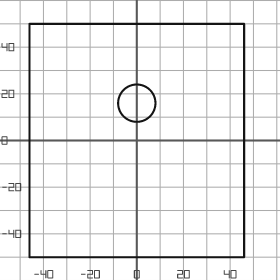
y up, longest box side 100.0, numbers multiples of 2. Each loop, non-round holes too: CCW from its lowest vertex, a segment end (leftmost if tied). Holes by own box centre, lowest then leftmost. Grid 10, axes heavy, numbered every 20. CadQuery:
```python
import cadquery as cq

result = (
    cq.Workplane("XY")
    .moveTo(-46.0, -50.0)
    .lineTo(46.0, -50.0)
    .lineTo(46.0, 50.0)
    .lineTo(-46.0, 50.0)
    .close()
    .moveTo(0.0, 16.0)
    .circle(8.0)
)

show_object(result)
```